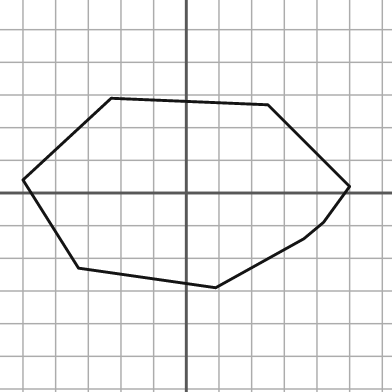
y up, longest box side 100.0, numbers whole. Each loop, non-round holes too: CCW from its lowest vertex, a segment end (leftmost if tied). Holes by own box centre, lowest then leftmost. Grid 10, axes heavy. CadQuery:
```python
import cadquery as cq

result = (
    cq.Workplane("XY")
    .moveTo(9.0, -29.0)
    .lineTo(36.0, -14.0)
    .lineTo(42.0, -9.0)
    .lineTo(50.0, 2.0)
    .lineTo(25.0, 27.0)
    .lineTo(-23.0, 29.0)
    .lineTo(-50.0, 4.0)
    .lineTo(-33.0, -23.0)
    .close()
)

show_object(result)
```